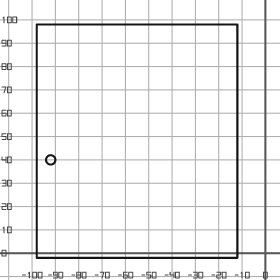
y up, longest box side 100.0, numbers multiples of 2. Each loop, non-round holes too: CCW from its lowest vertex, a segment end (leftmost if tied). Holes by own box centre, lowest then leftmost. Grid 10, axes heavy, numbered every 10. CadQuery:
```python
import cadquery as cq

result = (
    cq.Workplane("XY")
    .moveTo(-98.0, -2.0)
    .lineTo(-12.0, -2.0)
    .lineTo(-12.0, 98.0)
    .lineTo(-98.0, 98.0)
    .close()
    .moveTo(-92.0, 40.0)
    .circle(2.0)
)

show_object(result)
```